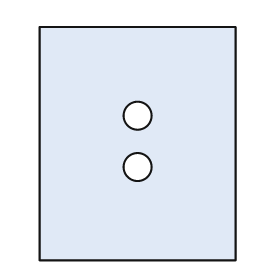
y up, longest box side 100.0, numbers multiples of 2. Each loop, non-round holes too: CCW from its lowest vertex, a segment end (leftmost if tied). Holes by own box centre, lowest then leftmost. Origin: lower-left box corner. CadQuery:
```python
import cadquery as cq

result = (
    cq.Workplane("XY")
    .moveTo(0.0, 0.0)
    .lineTo(84.0, 0.0)
    .lineTo(84.0, 100.0)
    .lineTo(0.0, 100.0)
    .close()
    .moveTo(42.0, 40.0)
    .circle(6.0)
    .moveTo(42.0, 62.0)
    .circle(6.0)
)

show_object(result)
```